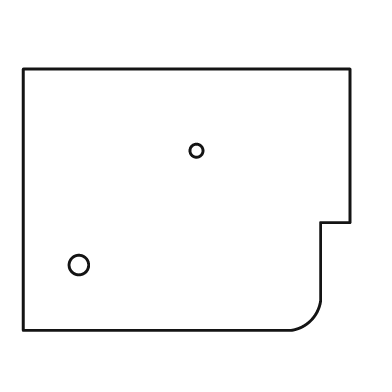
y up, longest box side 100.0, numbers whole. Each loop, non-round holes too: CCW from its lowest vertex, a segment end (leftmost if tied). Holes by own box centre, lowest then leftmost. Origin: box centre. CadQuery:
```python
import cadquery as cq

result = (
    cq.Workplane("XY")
    .moveTo(-50.0, -40.0)
    .lineTo(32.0, -40.0)
    .threePointArc((38.0, -37.0), (41.0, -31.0))
    .lineTo(41.0, -7.0)
    .lineTo(50.0, -7.0)
    .lineTo(50.0, 40.0)
    .lineTo(-50.0, 40.0)
    .close()
    .moveTo(-33.0, -20.0)
    .circle(3.0)
    .moveTo(3.0, 15.0)
    .circle(2.0)
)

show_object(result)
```